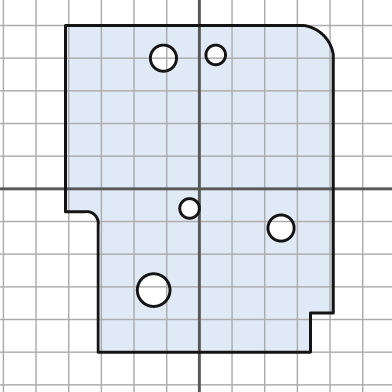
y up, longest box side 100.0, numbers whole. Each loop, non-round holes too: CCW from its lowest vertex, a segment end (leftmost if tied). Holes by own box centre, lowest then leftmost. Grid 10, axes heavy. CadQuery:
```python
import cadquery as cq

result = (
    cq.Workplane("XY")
    .moveTo(-31.0, -50.0)
    .lineTo(34.0, -50.0)
    .lineTo(34.0, -38.0)
    .lineTo(41.0, -38.0)
    .lineTo(41.0, 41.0)
    .threePointArc((38.0, 47.0), (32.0, 50.0))
    .lineTo(-41.0, 50.0)
    .lineTo(-41.0, -7.0)
    .lineTo(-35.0, -7.0)
    .threePointArc((-32.0, -8.0), (-31.0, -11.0))
    .close()
    .moveTo(-14.0, -31.0)
    .circle(5.0)
    .moveTo(25.0, -12.0)
    .circle(4.0)
    .moveTo(-3.0, -6.0)
    .circle(3.0)
    .moveTo(-11.0, 40.0)
    .circle(4.0)
    .moveTo(5.0, 41.0)
    .circle(3.0)
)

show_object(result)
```